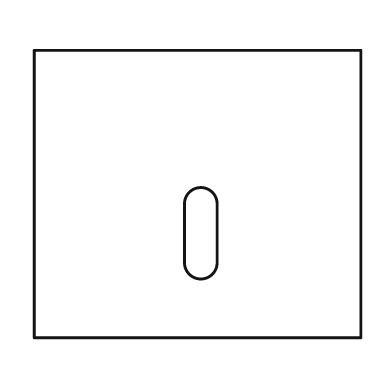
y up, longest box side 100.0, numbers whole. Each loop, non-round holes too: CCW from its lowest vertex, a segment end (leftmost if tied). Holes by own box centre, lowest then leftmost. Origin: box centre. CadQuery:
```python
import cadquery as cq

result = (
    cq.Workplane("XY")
    .moveTo(-50.0, -44.0)
    .lineTo(50.0, -44.0)
    .lineTo(50.0, 44.0)
    .lineTo(-50.0, 44.0)
    .close()
    .moveTo(-4.0, -21.0)
    .threePointArc((1.0, -26.0), (6.0, -21.0))
    .lineTo(6.0, -3.0)
    .threePointArc((1.0, 2.0), (-4.0, -3.0))
    .close()
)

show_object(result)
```